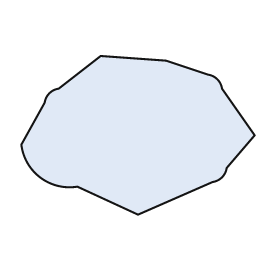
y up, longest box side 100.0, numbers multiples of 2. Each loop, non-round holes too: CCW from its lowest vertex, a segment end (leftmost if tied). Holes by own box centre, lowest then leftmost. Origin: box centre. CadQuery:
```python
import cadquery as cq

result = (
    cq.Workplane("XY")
    .moveTo(0.0, -34.0)
    .lineTo(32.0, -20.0)
    .threePointArc((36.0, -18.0), (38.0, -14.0))
    .lineTo(50.0, 0.0)
    .lineTo(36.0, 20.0)
    .threePointArc((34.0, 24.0), (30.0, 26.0))
    .lineTo(12.0, 32.0)
    .lineTo(-16.0, 34.0)
    .lineTo(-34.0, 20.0)
    .threePointArc((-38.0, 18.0), (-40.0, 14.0))
    .lineTo(-50.0, -4.0)
    .threePointArc((-42.0, -18.0), (-26.0, -22.0))
    .close()
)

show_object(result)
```